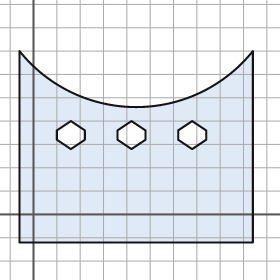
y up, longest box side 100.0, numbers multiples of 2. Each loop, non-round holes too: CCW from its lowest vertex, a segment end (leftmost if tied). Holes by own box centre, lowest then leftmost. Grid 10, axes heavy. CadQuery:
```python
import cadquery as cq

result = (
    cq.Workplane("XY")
    .moveTo(-6.0, -12.0)
    .lineTo(94.0, -12.0)
    .lineTo(94.0, 70.0)
    .threePointArc((44.0, 46.0), (-6.0, 70.0))
    .close()
    .moveTo(16.0, 28.0)
    .lineTo(22.0, 32.0)
    .lineTo(22.0, 36.0)
    .lineTo(16.0, 40.0)
    .lineTo(10.0, 36.0)
    .lineTo(10.0, 32.0)
    .close()
    .moveTo(42.0, 28.0)
    .lineTo(48.0, 32.0)
    .lineTo(48.0, 36.0)
    .lineTo(42.0, 40.0)
    .lineTo(36.0, 36.0)
    .lineTo(36.0, 32.0)
    .close()
    .moveTo(68.0, 28.0)
    .lineTo(74.0, 32.0)
    .lineTo(74.0, 36.0)
    .lineTo(68.0, 40.0)
    .lineTo(62.0, 36.0)
    .lineTo(62.0, 32.0)
    .close()
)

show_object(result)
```